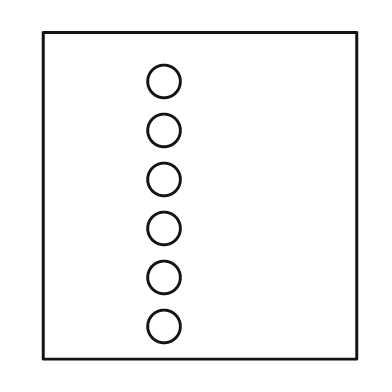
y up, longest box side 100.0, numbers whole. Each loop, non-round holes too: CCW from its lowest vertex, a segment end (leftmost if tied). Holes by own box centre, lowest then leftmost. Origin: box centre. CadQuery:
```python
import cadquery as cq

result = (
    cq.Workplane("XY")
    .moveTo(-48.0, -50.0)
    .lineTo(48.0, -50.0)
    .lineTo(48.0, 50.0)
    .lineTo(-48.0, 50.0)
    .close()
    .moveTo(-11.0, -40.0)
    .circle(5.0)
    .moveTo(-11.0, -25.0)
    .circle(5.0)
    .moveTo(-11.0, -10.0)
    .circle(5.0)
    .moveTo(-11.0, 5.0)
    .circle(5.0)
    .moveTo(-11.0, 20.0)
    .circle(5.0)
    .moveTo(-11.0, 35.0)
    .circle(5.0)
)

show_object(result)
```